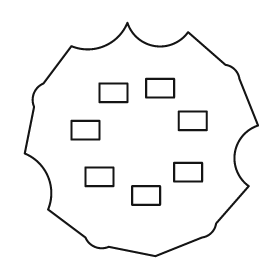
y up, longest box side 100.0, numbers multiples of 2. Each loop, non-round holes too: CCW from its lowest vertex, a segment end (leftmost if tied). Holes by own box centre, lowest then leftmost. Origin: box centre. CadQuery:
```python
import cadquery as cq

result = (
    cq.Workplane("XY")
    .moveTo(6.0, -50.0)
    .lineTo(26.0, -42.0)
    .threePointArc((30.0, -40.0), (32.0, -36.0))
    .lineTo(46.0, -20.0)
    .threePointArc((40.0, -6.0), (50.0, 6.0))
    .lineTo(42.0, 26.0)
    .threePointArc((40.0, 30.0), (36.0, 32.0))
    .lineTo(20.0, 46.0)
    .threePointArc((6.0, 40.0), (-6.0, 50.0))
    .threePointArc((-16.0, 40.0), (-30.0, 40.0))
    .lineTo(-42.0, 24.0)
    .threePointArc((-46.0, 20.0), (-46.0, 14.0))
    .lineTo(-50.0, -6.0)
    .threePointArc((-40.0, -16.0), (-40.0, -30.0))
    .lineTo(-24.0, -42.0)
    .threePointArc((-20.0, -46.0), (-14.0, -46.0))
    .close()
    .moveTo(-4.0, -28.0)
    .lineTo(8.0, -28.0)
    .lineTo(8.0, -20.0)
    .lineTo(-4.0, -20.0)
    .close()
    .moveTo(-24.0, -20.0)
    .lineTo(-12.0, -20.0)
    .lineTo(-12.0, -12.0)
    .lineTo(-24.0, -12.0)
    .close()
    .moveTo(14.0, -18.0)
    .lineTo(26.0, -18.0)
    .lineTo(26.0, -10.0)
    .lineTo(14.0, -10.0)
    .close()
    .moveTo(-30.0, 0.0)
    .lineTo(-18.0, 0.0)
    .lineTo(-18.0, 8.0)
    .lineTo(-30.0, 8.0)
    .close()
    .moveTo(16.0, 4.0)
    .lineTo(28.0, 4.0)
    .lineTo(28.0, 12.0)
    .lineTo(16.0, 12.0)
    .close()
    .moveTo(-18.0, 16.0)
    .lineTo(-6.0, 16.0)
    .lineTo(-6.0, 24.0)
    .lineTo(-18.0, 24.0)
    .close()
    .moveTo(2.0, 18.0)
    .lineTo(14.0, 18.0)
    .lineTo(14.0, 26.0)
    .lineTo(2.0, 26.0)
    .close()
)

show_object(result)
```